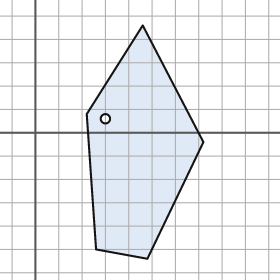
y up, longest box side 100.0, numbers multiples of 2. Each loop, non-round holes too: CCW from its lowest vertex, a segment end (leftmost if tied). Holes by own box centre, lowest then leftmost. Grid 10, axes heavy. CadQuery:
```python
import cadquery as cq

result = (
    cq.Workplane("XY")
    .moveTo(48.0, -54.0)
    .lineTo(72.0, -4.0)
    .lineTo(46.0, 46.0)
    .lineTo(22.0, 8.0)
    .lineTo(26.0, -50.0)
    .close()
    .moveTo(30.0, 6.0)
    .circle(2.0)
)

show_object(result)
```